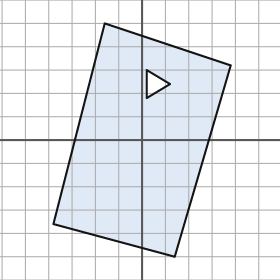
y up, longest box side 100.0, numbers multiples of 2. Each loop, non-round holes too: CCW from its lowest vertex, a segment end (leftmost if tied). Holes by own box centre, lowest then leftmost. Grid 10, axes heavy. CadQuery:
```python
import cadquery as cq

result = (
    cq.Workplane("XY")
    .moveTo(14.0, -50.0)
    .lineTo(38.0, 32.0)
    .lineTo(-16.0, 50.0)
    .lineTo(-38.0, -36.0)
    .close()
    .moveTo(2.0, 18.0)
    .lineTo(12.0, 24.0)
    .lineTo(2.0, 30.0)
    .close()
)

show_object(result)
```